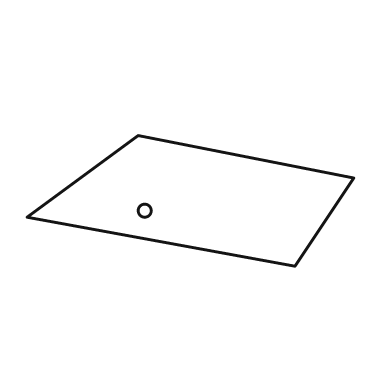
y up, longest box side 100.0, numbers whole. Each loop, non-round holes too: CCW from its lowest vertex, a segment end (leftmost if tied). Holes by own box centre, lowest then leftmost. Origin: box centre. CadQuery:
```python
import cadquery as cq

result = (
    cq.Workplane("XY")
    .moveTo(32.0, -20.0)
    .lineTo(50.0, 7.0)
    .lineTo(-16.0, 20.0)
    .lineTo(-50.0, -5.0)
    .close()
    .moveTo(-14.0, -3.0)
    .circle(2.0)
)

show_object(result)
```